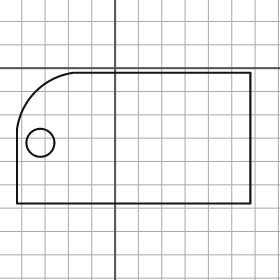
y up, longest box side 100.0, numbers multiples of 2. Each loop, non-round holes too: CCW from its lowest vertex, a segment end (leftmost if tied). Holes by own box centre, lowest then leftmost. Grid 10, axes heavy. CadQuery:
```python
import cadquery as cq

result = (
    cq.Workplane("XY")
    .moveTo(-42.0, -58.0)
    .lineTo(58.0, -58.0)
    .lineTo(58.0, -2.0)
    .lineTo(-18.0, -2.0)
    .threePointArc((-34.0, -10.0), (-42.0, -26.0))
    .close()
    .moveTo(-32.0, -32.0)
    .circle(6.0)
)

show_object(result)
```